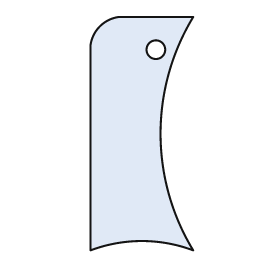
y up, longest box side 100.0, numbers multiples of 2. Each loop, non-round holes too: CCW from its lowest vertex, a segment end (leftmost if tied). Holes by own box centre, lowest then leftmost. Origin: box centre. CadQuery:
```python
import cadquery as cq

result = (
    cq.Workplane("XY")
    .moveTo(-22.0, -50.0)
    .threePointArc((0.0, -46.0), (22.0, -50.0))
    .threePointArc((8.0, 0.0), (22.0, 50.0))
    .lineTo(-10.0, 50.0)
    .threePointArc((-18.0, 46.0), (-22.0, 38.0))
    .close()
    .moveTo(6.0, 36.0)
    .circle(4.0)
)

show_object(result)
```